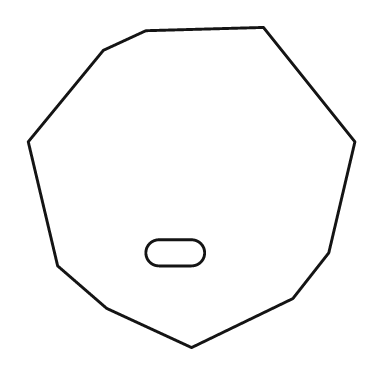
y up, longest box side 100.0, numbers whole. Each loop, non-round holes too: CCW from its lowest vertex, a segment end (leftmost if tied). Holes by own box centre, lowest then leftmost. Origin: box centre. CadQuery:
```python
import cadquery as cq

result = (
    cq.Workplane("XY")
    .moveTo(0.0, -49.0)
    .lineTo(31.0, -34.0)
    .lineTo(42.0, -20.0)
    .lineTo(50.0, 14.0)
    .lineTo(22.0, 49.0)
    .lineTo(-14.0, 48.0)
    .lineTo(-27.0, 42.0)
    .lineTo(-50.0, 14.0)
    .lineTo(-41.0, -24.0)
    .lineTo(-26.0, -37.0)
    .close()
    .moveTo(-10.0, -24.0)
    .lineTo(0.0, -24.0)
    .threePointArc((4.0, -20.0), (0.0, -16.0))
    .lineTo(-10.0, -16.0)
    .threePointArc((-14.0, -20.0), (-10.0, -24.0))
    .close()
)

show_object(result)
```